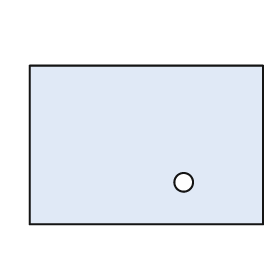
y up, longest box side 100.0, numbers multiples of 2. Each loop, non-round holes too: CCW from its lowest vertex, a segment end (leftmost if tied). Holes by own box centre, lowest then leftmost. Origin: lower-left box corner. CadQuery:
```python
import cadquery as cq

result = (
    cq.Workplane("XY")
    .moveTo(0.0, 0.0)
    .lineTo(100.0, 0.0)
    .lineTo(100.0, 68.0)
    .lineTo(0.0, 68.0)
    .close()
    .moveTo(66.0, 18.0)
    .circle(4.0)
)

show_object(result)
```